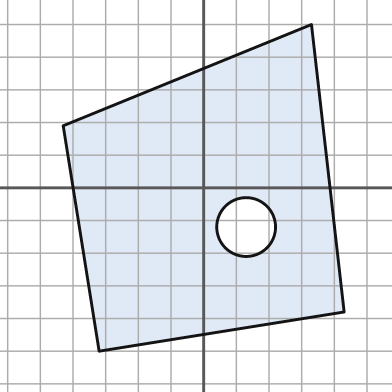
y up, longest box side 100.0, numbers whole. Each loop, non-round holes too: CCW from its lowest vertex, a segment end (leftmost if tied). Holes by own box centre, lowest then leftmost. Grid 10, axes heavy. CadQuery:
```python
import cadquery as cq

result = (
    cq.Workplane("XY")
    .moveTo(-32.0, -50.0)
    .lineTo(43.0, -38.0)
    .lineTo(33.0, 50.0)
    .lineTo(-43.0, 19.0)
    .close()
    .moveTo(13.0, -12.0)
    .circle(9.0)
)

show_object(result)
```